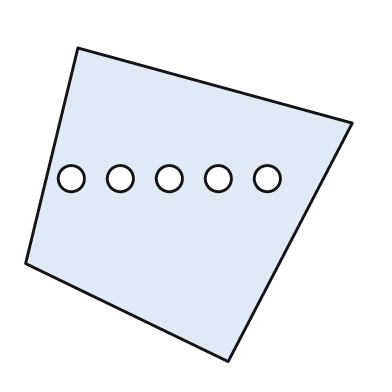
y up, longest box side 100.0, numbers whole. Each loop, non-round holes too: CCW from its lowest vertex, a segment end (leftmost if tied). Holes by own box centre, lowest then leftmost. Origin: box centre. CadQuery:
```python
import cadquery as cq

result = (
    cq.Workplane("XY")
    .moveTo(12.0, -48.0)
    .lineTo(50.0, 25.0)
    .lineTo(-34.0, 48.0)
    .lineTo(-50.0, -18.0)
    .close()
    .moveTo(-36.0, 8.0)
    .circle(4.0)
    .moveTo(-21.0, 8.0)
    .circle(4.0)
    .moveTo(-6.0, 8.0)
    .circle(4.0)
    .moveTo(9.0, 8.0)
    .circle(4.0)
    .moveTo(24.0, 8.0)
    .circle(4.0)
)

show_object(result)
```